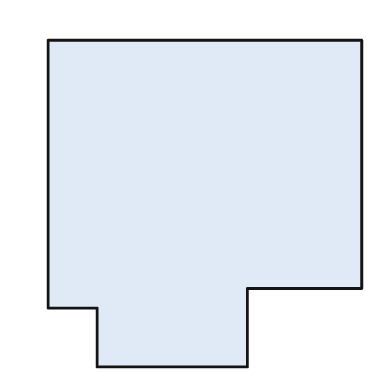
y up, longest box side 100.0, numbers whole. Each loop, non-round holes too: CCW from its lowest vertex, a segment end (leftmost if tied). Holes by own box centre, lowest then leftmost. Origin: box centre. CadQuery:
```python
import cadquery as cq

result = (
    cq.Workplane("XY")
    .moveTo(-33.0, -50.0)
    .lineTo(13.0, -50.0)
    .lineTo(13.0, -26.0)
    .lineTo(48.0, -26.0)
    .lineTo(48.0, 50.0)
    .lineTo(-48.0, 50.0)
    .lineTo(-48.0, -32.0)
    .lineTo(-33.0, -32.0)
    .close()
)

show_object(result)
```